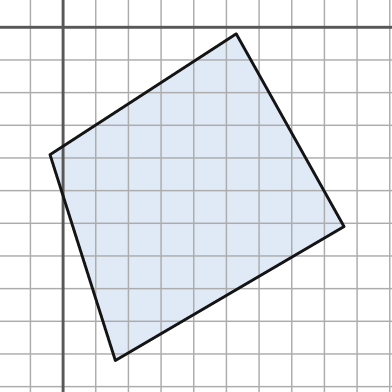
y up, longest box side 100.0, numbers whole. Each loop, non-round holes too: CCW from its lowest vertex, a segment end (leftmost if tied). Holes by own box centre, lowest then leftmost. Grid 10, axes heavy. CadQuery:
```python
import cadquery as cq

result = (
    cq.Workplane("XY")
    .moveTo(16.0, -102.0)
    .lineTo(86.0, -61.0)
    .lineTo(53.0, -2.0)
    .lineTo(-4.0, -39.0)
    .close()
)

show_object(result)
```